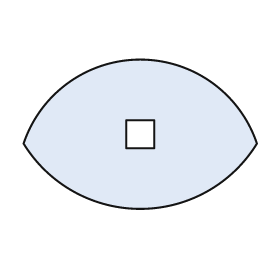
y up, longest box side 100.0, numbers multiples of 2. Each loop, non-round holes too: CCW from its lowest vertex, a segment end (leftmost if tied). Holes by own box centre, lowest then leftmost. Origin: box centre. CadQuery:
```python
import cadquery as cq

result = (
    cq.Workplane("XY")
    .moveTo(-50.0, -4.0)
    .threePointArc((0.0, -32.0), (50.0, -4.0))
    .threePointArc((0.0, 32.0), (-50.0, -4.0))
    .close()
    .moveTo(-6.0, -6.0)
    .lineTo(6.0, -6.0)
    .lineTo(6.0, 6.0)
    .lineTo(-6.0, 6.0)
    .close()
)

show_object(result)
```